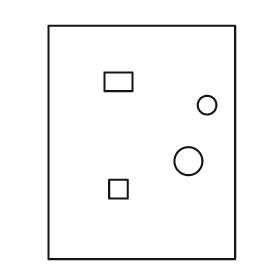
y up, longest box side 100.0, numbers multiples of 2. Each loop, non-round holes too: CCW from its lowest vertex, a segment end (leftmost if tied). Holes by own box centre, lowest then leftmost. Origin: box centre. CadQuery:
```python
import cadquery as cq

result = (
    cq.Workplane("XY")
    .moveTo(-40.0, -50.0)
    .lineTo(40.0, -50.0)
    .lineTo(40.0, 50.0)
    .lineTo(-40.0, 50.0)
    .close()
    .moveTo(-14.0, -24.0)
    .lineTo(-6.0, -24.0)
    .lineTo(-6.0, -16.0)
    .lineTo(-14.0, -16.0)
    .close()
    .moveTo(20.0, -8.0)
    .circle(6.0)
    .moveTo(28.0, 16.0)
    .circle(4.0)
    .moveTo(-16.0, 22.0)
    .lineTo(-4.0, 22.0)
    .lineTo(-4.0, 30.0)
    .lineTo(-16.0, 30.0)
    .close()
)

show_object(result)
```